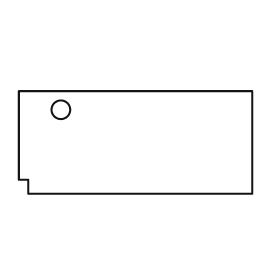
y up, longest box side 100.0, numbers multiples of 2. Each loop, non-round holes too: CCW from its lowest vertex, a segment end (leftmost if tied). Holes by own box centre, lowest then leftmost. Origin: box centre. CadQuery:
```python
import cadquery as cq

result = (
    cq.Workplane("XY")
    .moveTo(-46.0, -22.0)
    .lineTo(50.0, -22.0)
    .lineTo(50.0, 22.0)
    .lineTo(-50.0, 22.0)
    .lineTo(-50.0, -16.0)
    .lineTo(-46.0, -16.0)
    .close()
    .moveTo(-32.0, 14.0)
    .circle(4.0)
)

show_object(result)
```